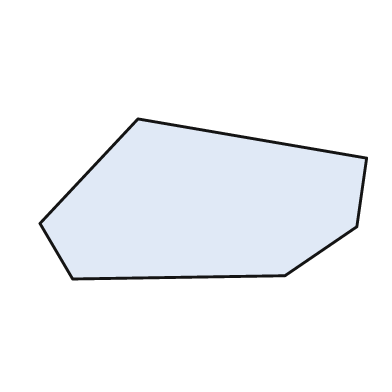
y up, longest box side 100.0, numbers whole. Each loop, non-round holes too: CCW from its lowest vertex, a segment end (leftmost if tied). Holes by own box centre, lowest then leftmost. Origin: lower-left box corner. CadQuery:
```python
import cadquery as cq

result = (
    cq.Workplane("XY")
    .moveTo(10.0, 0.0)
    .lineTo(75.0, 1.0)
    .lineTo(97.0, 16.0)
    .lineTo(100.0, 37.0)
    .lineTo(30.0, 49.0)
    .lineTo(0.0, 17.0)
    .close()
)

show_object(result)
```